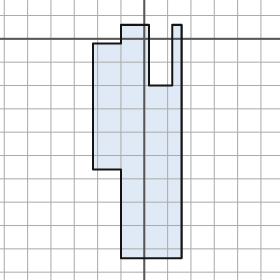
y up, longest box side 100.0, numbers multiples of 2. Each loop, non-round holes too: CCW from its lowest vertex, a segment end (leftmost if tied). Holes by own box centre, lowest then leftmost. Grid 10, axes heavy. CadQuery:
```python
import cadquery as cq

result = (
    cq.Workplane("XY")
    .moveTo(-10.0, -94.0)
    .lineTo(16.0, -94.0)
    .lineTo(16.0, 6.0)
    .lineTo(12.0, 6.0)
    .lineTo(12.0, -20.0)
    .lineTo(2.0, -20.0)
    .lineTo(2.0, 6.0)
    .lineTo(-10.0, 6.0)
    .lineTo(-10.0, -2.0)
    .lineTo(-22.0, -2.0)
    .lineTo(-22.0, -56.0)
    .lineTo(-10.0, -56.0)
    .close()
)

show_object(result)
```